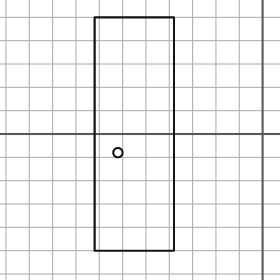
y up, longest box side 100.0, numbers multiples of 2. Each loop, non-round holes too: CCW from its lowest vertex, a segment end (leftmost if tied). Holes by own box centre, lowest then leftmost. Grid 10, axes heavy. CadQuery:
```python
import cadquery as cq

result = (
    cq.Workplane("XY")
    .moveTo(-72.0, -50.0)
    .lineTo(-38.0, -50.0)
    .lineTo(-38.0, 50.0)
    .lineTo(-72.0, 50.0)
    .close()
    .moveTo(-62.0, -8.0)
    .circle(2.0)
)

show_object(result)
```